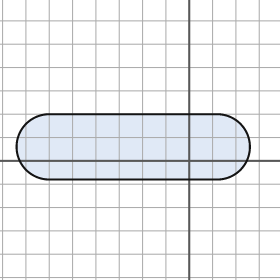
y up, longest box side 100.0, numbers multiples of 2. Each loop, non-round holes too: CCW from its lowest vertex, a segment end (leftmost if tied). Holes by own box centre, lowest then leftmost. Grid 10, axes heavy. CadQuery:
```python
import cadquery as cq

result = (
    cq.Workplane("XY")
    .moveTo(-60.0, -8.0)
    .lineTo(12.0, -8.0)
    .threePointArc((26.0, 6.0), (12.0, 20.0))
    .lineTo(-60.0, 20.0)
    .threePointArc((-74.0, 6.0), (-60.0, -8.0))
    .close()
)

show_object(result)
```